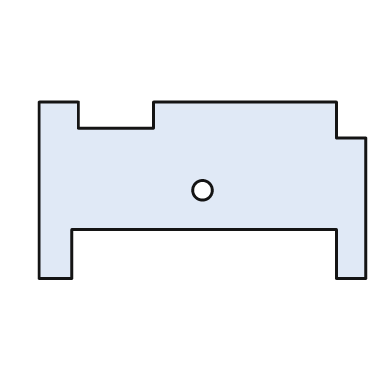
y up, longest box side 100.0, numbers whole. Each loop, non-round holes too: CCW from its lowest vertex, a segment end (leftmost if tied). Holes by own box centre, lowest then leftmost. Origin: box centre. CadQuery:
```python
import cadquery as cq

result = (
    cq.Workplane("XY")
    .moveTo(-50.0, -27.0)
    .lineTo(-40.0, -27.0)
    .lineTo(-40.0, -12.0)
    .lineTo(41.0, -12.0)
    .lineTo(41.0, -27.0)
    .lineTo(50.0, -27.0)
    .lineTo(50.0, 16.0)
    .lineTo(41.0, 16.0)
    .lineTo(41.0, 27.0)
    .lineTo(-15.0, 27.0)
    .lineTo(-15.0, 19.0)
    .lineTo(-38.0, 19.0)
    .lineTo(-38.0, 27.0)
    .lineTo(-50.0, 27.0)
    .close()
    .moveTo(0.0, 0.0)
    .circle(3.0)
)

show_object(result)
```